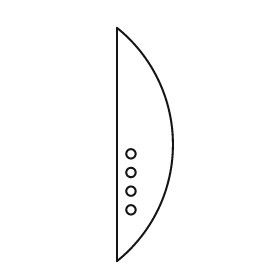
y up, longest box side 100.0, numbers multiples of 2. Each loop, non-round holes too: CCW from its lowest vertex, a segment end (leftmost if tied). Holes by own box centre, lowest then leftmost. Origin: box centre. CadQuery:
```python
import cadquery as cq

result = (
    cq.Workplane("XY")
    .moveTo(-12.0, -50.0)
    .threePointArc((12.0, 0.0), (-12.0, 50.0))
    .close()
    .moveTo(-6.0, -28.0)
    .circle(2.0)
    .moveTo(-6.0, -20.0)
    .circle(2.0)
    .moveTo(-6.0, -12.0)
    .circle(2.0)
    .moveTo(-6.0, -4.0)
    .circle(2.0)
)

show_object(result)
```